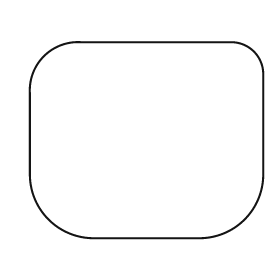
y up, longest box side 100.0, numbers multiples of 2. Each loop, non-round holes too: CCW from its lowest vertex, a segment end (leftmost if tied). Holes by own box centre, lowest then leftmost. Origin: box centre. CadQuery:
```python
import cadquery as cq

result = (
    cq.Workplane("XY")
    .moveTo(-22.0, -42.0)
    .lineTo(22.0, -42.0)
    .threePointArc((42.0, -34.0), (50.0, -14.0))
    .lineTo(50.0, 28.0)
    .threePointArc((46.0, 38.0), (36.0, 42.0))
    .lineTo(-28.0, 42.0)
    .threePointArc((-44.0, 36.0), (-50.0, 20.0))
    .lineTo(-50.0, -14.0)
    .threePointArc((-42.0, -34.0), (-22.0, -42.0))
    .close()
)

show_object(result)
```